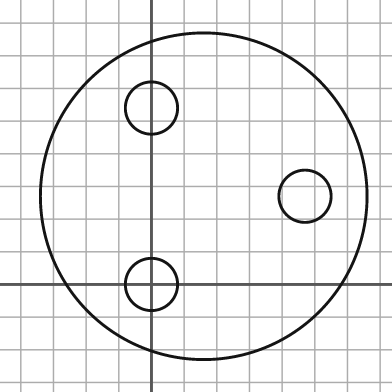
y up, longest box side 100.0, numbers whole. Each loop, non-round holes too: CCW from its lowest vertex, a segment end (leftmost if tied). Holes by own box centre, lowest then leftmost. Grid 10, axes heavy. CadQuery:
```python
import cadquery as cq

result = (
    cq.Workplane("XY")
    .moveTo(16.0, 27.0)
    .circle(50.0)
    .moveTo(0.0, 0.0)
    .circle(8.0)
    .moveTo(47.0, 27.0)
    .circle(8.0)
    .moveTo(0.0, 54.0)
    .circle(8.0)
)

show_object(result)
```